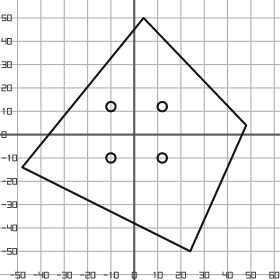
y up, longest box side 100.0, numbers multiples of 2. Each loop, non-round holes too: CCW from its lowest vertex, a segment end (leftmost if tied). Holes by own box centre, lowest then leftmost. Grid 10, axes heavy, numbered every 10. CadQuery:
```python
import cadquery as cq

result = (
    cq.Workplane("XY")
    .moveTo(24.0, -50.0)
    .lineTo(48.0, 4.0)
    .lineTo(4.0, 50.0)
    .lineTo(-48.0, -14.0)
    .close()
    .moveTo(-10.0, -10.0)
    .circle(2.0)
    .moveTo(12.0, -10.0)
    .circle(2.0)
    .moveTo(-10.0, 12.0)
    .circle(2.0)
    .moveTo(12.0, 12.0)
    .circle(2.0)
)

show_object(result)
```